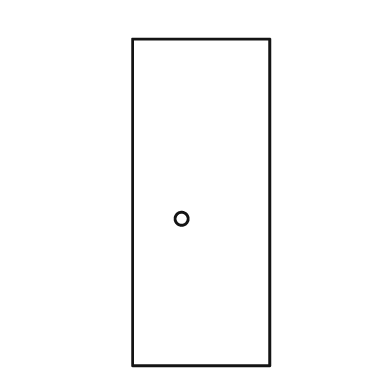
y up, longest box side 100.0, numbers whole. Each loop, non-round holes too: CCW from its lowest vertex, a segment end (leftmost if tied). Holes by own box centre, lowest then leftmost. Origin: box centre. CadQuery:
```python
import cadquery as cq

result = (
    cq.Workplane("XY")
    .moveTo(-21.0, -50.0)
    .lineTo(21.0, -50.0)
    .lineTo(21.0, 50.0)
    .lineTo(-21.0, 50.0)
    .close()
    .moveTo(-6.0, -5.0)
    .circle(2.0)
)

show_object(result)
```